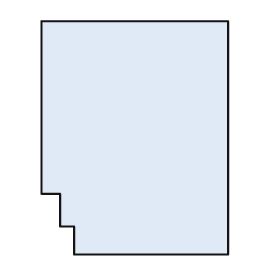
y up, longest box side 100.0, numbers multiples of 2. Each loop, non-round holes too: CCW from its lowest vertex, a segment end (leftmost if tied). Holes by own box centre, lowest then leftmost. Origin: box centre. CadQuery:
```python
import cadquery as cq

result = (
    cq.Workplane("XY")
    .moveTo(-26.0, -50.0)
    .lineTo(40.0, -50.0)
    .lineTo(40.0, 50.0)
    .lineTo(-40.0, 50.0)
    .lineTo(-40.0, -24.0)
    .lineTo(-32.0, -24.0)
    .lineTo(-32.0, -38.0)
    .lineTo(-26.0, -38.0)
    .close()
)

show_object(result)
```